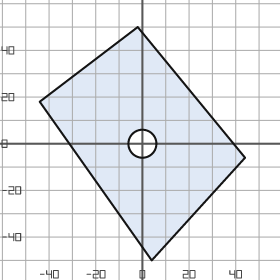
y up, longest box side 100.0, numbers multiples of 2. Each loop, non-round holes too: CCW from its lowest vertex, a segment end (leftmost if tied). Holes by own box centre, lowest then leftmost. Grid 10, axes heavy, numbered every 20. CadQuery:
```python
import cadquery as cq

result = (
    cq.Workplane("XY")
    .moveTo(4.0, -50.0)
    .lineTo(44.0, -6.0)
    .lineTo(-2.0, 50.0)
    .lineTo(-44.0, 18.0)
    .close()
    .moveTo(0.0, 0.0)
    .circle(6.0)
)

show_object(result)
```